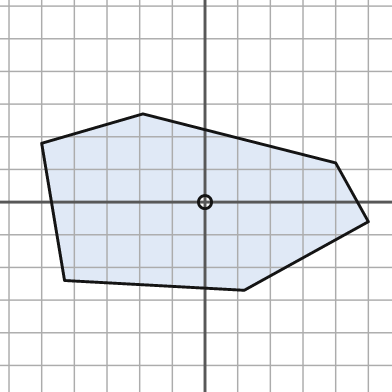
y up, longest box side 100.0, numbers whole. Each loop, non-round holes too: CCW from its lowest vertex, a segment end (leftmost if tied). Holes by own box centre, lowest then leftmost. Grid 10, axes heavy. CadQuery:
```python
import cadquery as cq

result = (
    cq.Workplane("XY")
    .moveTo(12.0, -27.0)
    .lineTo(50.0, -6.0)
    .lineTo(40.0, 12.0)
    .lineTo(-19.0, 27.0)
    .lineTo(-50.0, 18.0)
    .lineTo(-43.0, -24.0)
    .close()
    .moveTo(0.0, 0.0)
    .circle(2.0)
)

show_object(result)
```